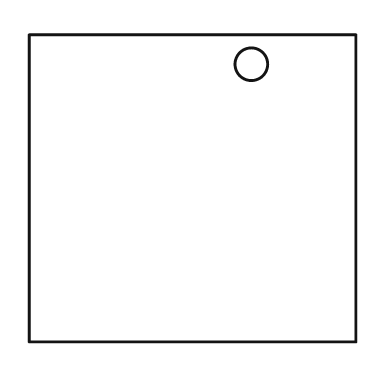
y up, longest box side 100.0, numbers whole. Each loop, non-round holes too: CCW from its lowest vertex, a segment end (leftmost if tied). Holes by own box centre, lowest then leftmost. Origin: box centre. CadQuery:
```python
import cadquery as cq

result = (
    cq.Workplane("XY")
    .moveTo(-50.0, -47.0)
    .lineTo(50.0, -47.0)
    .lineTo(50.0, 47.0)
    .lineTo(-50.0, 47.0)
    .close()
    .moveTo(18.0, 38.0)
    .circle(5.0)
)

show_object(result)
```